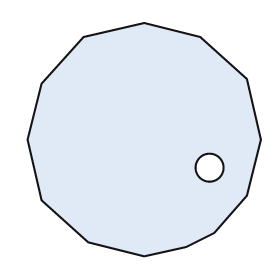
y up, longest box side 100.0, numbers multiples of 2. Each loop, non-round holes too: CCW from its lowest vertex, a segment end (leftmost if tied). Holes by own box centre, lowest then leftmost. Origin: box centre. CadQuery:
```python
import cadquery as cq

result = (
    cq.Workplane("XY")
    .moveTo(0.0, -50.0)
    .lineTo(18.0, -46.0)
    .lineTo(30.0, -40.0)
    .lineTo(44.0, -24.0)
    .lineTo(50.0, 0.0)
    .lineTo(44.0, 26.0)
    .lineTo(24.0, 44.0)
    .lineTo(0.0, 50.0)
    .lineTo(-26.0, 44.0)
    .lineTo(-44.0, 24.0)
    .lineTo(-50.0, 0.0)
    .lineTo(-44.0, -26.0)
    .lineTo(-24.0, -44.0)
    .close()
    .moveTo(28.0, -12.0)
    .circle(6.0)
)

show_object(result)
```